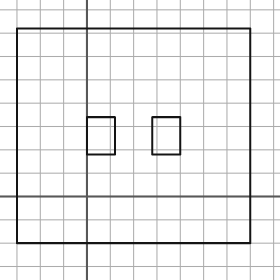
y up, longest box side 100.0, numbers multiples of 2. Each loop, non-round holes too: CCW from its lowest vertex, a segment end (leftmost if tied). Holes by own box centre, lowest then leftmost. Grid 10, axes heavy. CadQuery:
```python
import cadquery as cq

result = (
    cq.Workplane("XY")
    .moveTo(-30.0, -20.0)
    .lineTo(70.0, -20.0)
    .lineTo(70.0, 72.0)
    .lineTo(-30.0, 72.0)
    .close()
    .moveTo(0.0, 18.0)
    .lineTo(12.0, 18.0)
    .lineTo(12.0, 34.0)
    .lineTo(0.0, 34.0)
    .close()
    .moveTo(28.0, 18.0)
    .lineTo(40.0, 18.0)
    .lineTo(40.0, 34.0)
    .lineTo(28.0, 34.0)
    .close()
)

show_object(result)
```